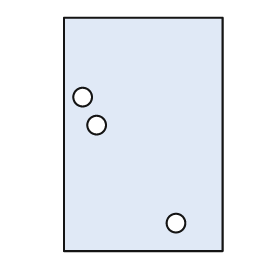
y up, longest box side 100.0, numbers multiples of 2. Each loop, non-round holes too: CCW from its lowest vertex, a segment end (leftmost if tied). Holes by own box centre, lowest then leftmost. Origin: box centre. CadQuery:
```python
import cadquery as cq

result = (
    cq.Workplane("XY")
    .moveTo(-34.0, -50.0)
    .lineTo(34.0, -50.0)
    .lineTo(34.0, 50.0)
    .lineTo(-34.0, 50.0)
    .close()
    .moveTo(14.0, -38.0)
    .circle(4.0)
    .moveTo(-20.0, 4.0)
    .circle(4.0)
    .moveTo(-26.0, 16.0)
    .circle(4.0)
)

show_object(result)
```